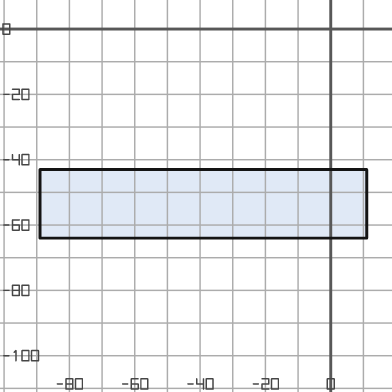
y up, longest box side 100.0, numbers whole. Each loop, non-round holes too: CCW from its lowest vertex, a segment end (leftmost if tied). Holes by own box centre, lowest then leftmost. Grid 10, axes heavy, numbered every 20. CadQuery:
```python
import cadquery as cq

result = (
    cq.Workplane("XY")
    .moveTo(-89.0, -64.0)
    .lineTo(11.0, -64.0)
    .lineTo(11.0, -43.0)
    .lineTo(-89.0, -43.0)
    .close()
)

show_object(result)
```